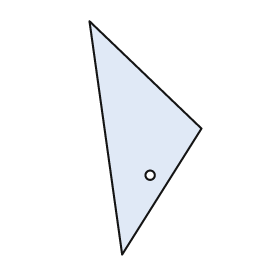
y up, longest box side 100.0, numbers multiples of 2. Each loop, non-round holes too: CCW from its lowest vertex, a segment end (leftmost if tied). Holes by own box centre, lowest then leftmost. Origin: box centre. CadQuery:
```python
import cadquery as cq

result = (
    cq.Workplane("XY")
    .moveTo(-10.0, -50.0)
    .lineTo(24.0, 4.0)
    .lineTo(-24.0, 50.0)
    .close()
    .moveTo(2.0, -16.0)
    .circle(2.0)
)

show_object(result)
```